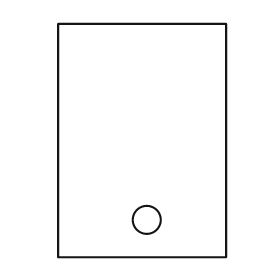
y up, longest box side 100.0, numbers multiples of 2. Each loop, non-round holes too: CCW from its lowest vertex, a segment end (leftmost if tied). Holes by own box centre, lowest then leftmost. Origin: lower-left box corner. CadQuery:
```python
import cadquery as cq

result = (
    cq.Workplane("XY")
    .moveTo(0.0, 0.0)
    .lineTo(72.0, 0.0)
    .lineTo(72.0, 100.0)
    .lineTo(0.0, 100.0)
    .close()
    .moveTo(38.0, 16.0)
    .circle(6.0)
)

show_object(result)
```